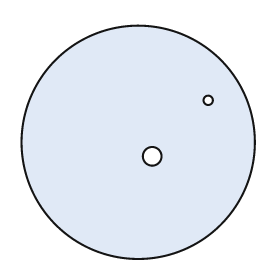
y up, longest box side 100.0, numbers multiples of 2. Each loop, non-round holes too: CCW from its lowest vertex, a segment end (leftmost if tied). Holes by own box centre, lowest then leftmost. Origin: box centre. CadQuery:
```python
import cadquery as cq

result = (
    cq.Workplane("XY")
    .moveTo(0.0, 0.0)
    .circle(50.0)
    .moveTo(6.0, -6.0)
    .circle(4.0)
    .moveTo(30.0, 18.0)
    .circle(2.0)
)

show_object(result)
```